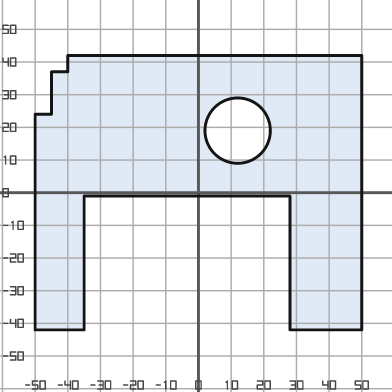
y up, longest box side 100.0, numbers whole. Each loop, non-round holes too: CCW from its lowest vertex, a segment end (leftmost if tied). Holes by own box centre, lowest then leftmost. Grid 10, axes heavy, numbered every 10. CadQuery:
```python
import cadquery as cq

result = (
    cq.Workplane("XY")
    .moveTo(-50.0, -42.0)
    .lineTo(-35.0, -42.0)
    .lineTo(-35.0, -1.0)
    .lineTo(28.0, -1.0)
    .lineTo(28.0, -42.0)
    .lineTo(50.0, -42.0)
    .lineTo(50.0, 42.0)
    .lineTo(-40.0, 42.0)
    .lineTo(-40.0, 37.0)
    .lineTo(-45.0, 37.0)
    .lineTo(-45.0, 24.0)
    .lineTo(-50.0, 24.0)
    .close()
    .moveTo(12.0, 19.0)
    .circle(10.0)
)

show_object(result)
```